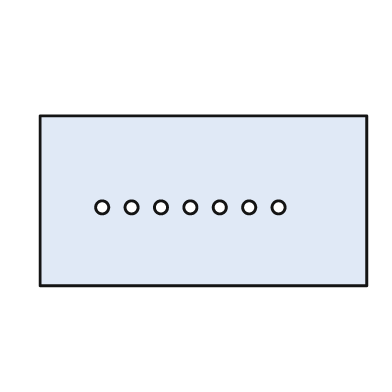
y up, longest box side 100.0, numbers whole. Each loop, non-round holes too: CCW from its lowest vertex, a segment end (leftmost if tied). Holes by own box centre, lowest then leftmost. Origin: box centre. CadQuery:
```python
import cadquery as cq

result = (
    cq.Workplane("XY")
    .moveTo(-50.0, -26.0)
    .lineTo(50.0, -26.0)
    .lineTo(50.0, 26.0)
    .lineTo(-50.0, 26.0)
    .close()
    .moveTo(-31.0, -2.0)
    .circle(2.0)
    .moveTo(-22.0, -2.0)
    .circle(2.0)
    .moveTo(-13.0, -2.0)
    .circle(2.0)
    .moveTo(-4.0, -2.0)
    .circle(2.0)
    .moveTo(5.0, -2.0)
    .circle(2.0)
    .moveTo(14.0, -2.0)
    .circle(2.0)
    .moveTo(23.0, -2.0)
    .circle(2.0)
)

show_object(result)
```